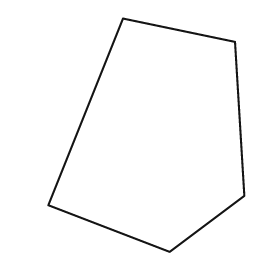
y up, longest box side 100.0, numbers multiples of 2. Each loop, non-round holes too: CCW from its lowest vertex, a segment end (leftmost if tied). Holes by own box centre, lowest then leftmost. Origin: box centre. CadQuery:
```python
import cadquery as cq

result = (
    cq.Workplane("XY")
    .moveTo(10.0, -50.0)
    .lineTo(42.0, -26.0)
    .lineTo(38.0, 40.0)
    .lineTo(-10.0, 50.0)
    .lineTo(-42.0, -30.0)
    .close()
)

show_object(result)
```